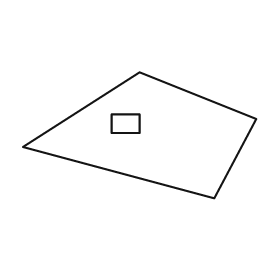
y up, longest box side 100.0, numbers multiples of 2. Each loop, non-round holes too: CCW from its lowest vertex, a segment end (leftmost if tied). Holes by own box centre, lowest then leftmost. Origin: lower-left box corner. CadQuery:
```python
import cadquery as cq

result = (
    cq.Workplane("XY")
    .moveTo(82.0, 0.0)
    .lineTo(100.0, 34.0)
    .lineTo(50.0, 54.0)
    .lineTo(0.0, 22.0)
    .close()
    .moveTo(38.0, 28.0)
    .lineTo(50.0, 28.0)
    .lineTo(50.0, 36.0)
    .lineTo(38.0, 36.0)
    .close()
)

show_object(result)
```